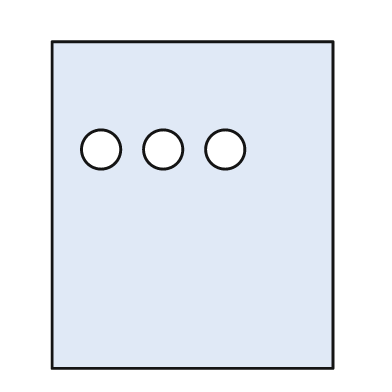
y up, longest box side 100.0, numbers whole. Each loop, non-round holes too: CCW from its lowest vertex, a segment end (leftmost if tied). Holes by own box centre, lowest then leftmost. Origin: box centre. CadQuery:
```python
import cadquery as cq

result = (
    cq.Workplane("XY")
    .moveTo(-43.0, -50.0)
    .lineTo(43.0, -50.0)
    .lineTo(43.0, 50.0)
    .lineTo(-43.0, 50.0)
    .close()
    .moveTo(-28.0, 17.0)
    .circle(6.0)
    .moveTo(-9.0, 17.0)
    .circle(6.0)
    .moveTo(10.0, 17.0)
    .circle(6.0)
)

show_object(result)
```